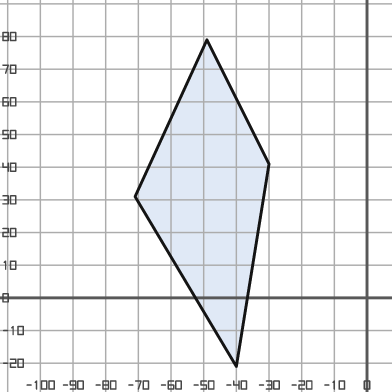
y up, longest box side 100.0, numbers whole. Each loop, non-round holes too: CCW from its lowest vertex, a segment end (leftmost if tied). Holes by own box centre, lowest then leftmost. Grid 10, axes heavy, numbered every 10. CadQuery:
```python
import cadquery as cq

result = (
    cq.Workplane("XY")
    .moveTo(-40.0, -21.0)
    .lineTo(-30.0, 41.0)
    .lineTo(-49.0, 79.0)
    .lineTo(-71.0, 31.0)
    .close()
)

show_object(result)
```